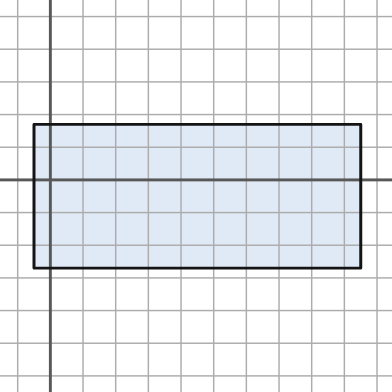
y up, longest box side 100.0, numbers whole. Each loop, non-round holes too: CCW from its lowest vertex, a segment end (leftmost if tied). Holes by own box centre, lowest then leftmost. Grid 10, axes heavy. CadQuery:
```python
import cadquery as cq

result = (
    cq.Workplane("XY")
    .moveTo(-5.0, -27.0)
    .lineTo(95.0, -27.0)
    .lineTo(95.0, 17.0)
    .lineTo(-5.0, 17.0)
    .close()
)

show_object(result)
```